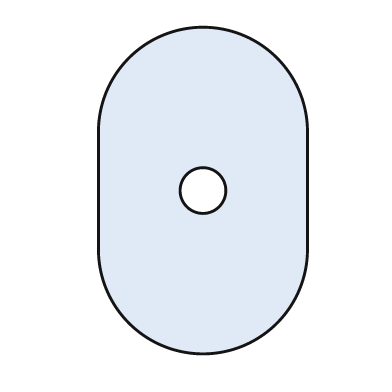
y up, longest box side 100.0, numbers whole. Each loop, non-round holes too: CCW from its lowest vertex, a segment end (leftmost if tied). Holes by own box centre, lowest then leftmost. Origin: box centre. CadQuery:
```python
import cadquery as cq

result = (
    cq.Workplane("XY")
    .moveTo(-32.0, -18.0)
    .threePointArc((0.0, -50.0), (32.0, -18.0))
    .lineTo(32.0, 18.0)
    .threePointArc((0.0, 50.0), (-32.0, 18.0))
    .close()
    .moveTo(0.0, 0.0)
    .circle(7.0)
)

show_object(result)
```